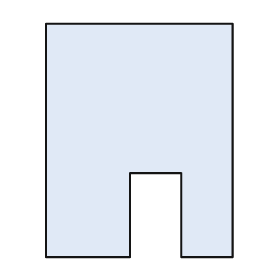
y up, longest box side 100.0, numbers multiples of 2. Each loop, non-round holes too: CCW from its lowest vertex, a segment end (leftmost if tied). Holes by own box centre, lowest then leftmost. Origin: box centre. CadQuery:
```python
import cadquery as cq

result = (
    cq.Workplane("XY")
    .moveTo(-40.0, -50.0)
    .lineTo(-4.0, -50.0)
    .lineTo(-4.0, -14.0)
    .lineTo(18.0, -14.0)
    .lineTo(18.0, -50.0)
    .lineTo(40.0, -50.0)
    .lineTo(40.0, 50.0)
    .lineTo(-40.0, 50.0)
    .close()
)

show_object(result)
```